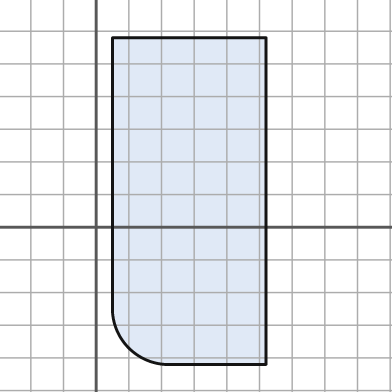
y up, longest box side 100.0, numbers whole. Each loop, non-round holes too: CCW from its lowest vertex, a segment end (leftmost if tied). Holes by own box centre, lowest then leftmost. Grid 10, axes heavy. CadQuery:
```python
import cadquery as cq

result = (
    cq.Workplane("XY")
    .moveTo(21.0, -42.0)
    .lineTo(52.0, -42.0)
    .lineTo(52.0, 58.0)
    .lineTo(5.0, 58.0)
    .lineTo(5.0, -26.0)
    .threePointArc((10.0, -37.0), (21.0, -42.0))
    .close()
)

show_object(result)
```